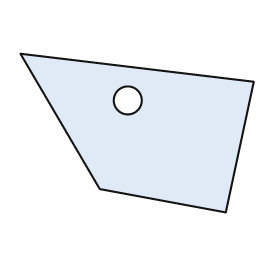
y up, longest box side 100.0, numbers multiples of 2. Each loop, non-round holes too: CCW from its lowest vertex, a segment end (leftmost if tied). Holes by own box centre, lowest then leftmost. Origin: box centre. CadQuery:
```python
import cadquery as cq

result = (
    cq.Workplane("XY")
    .moveTo(38.0, -34.0)
    .lineTo(50.0, 22.0)
    .lineTo(-50.0, 34.0)
    .lineTo(-16.0, -24.0)
    .close()
    .moveTo(-4.0, 14.0)
    .circle(6.0)
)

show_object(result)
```